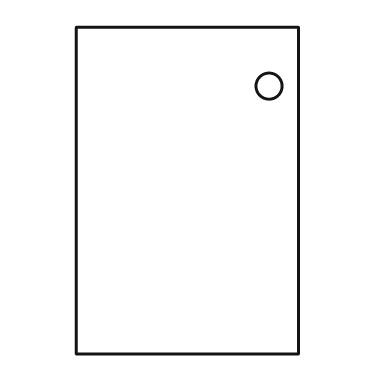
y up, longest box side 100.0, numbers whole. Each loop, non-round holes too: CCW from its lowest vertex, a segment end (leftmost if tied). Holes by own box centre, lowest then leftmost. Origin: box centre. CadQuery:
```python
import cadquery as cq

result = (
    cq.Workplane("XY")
    .moveTo(-34.0, -50.0)
    .lineTo(34.0, -50.0)
    .lineTo(34.0, 50.0)
    .lineTo(-34.0, 50.0)
    .close()
    .moveTo(25.0, 32.0)
    .circle(4.0)
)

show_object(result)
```